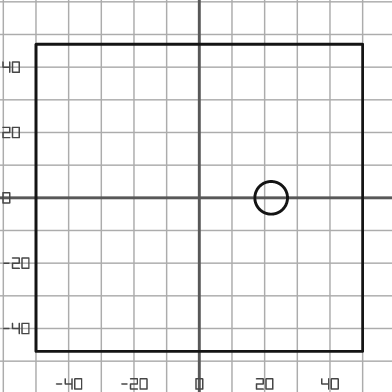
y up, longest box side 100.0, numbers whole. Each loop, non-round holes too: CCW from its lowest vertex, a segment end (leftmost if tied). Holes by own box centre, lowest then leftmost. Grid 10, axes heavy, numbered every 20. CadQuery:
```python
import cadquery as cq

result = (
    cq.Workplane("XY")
    .moveTo(-50.0, -47.0)
    .lineTo(50.0, -47.0)
    .lineTo(50.0, 47.0)
    .lineTo(-50.0, 47.0)
    .close()
    .moveTo(22.0, 0.0)
    .circle(5.0)
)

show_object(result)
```